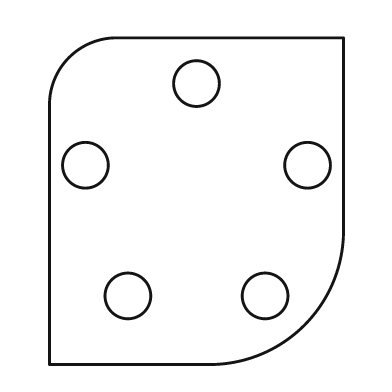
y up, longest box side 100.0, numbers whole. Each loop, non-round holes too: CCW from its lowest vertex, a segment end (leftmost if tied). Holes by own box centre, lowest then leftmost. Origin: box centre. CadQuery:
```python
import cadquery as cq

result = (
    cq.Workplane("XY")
    .moveTo(-45.0, -50.0)
    .lineTo(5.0, -50.0)
    .threePointArc((33.0, -38.0), (45.0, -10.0))
    .lineTo(45.0, 50.0)
    .lineTo(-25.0, 50.0)
    .threePointArc((-39.0, 44.0), (-45.0, 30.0))
    .close()
    .moveTo(-21.0, -29.0)
    .circle(7.0)
    .moveTo(21.0, -29.0)
    .circle(7.0)
    .moveTo(-34.0, 11.0)
    .circle(7.0)
    .moveTo(34.0, 11.0)
    .circle(7.0)
    .moveTo(0.0, 36.0)
    .circle(7.0)
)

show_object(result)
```